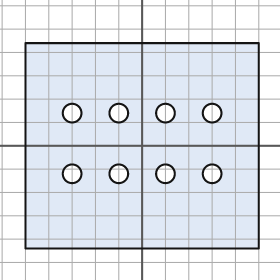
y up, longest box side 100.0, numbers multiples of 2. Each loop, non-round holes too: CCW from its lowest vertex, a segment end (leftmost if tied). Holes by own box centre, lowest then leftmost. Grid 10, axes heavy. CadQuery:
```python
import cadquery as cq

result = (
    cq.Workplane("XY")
    .moveTo(-50.0, -44.0)
    .lineTo(50.0, -44.0)
    .lineTo(50.0, 44.0)
    .lineTo(-50.0, 44.0)
    .close()
    .moveTo(-30.0, -12.0)
    .circle(4.0)
    .moveTo(-10.0, -12.0)
    .circle(4.0)
    .moveTo(10.0, -12.0)
    .circle(4.0)
    .moveTo(30.0, -12.0)
    .circle(4.0)
    .moveTo(-30.0, 14.0)
    .circle(4.0)
    .moveTo(-10.0, 14.0)
    .circle(4.0)
    .moveTo(10.0, 14.0)
    .circle(4.0)
    .moveTo(30.0, 14.0)
    .circle(4.0)
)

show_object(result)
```